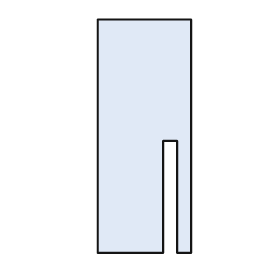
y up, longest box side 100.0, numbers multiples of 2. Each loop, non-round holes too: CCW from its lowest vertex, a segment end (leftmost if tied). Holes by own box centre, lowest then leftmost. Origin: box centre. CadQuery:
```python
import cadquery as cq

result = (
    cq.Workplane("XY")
    .moveTo(-20.0, -50.0)
    .lineTo(8.0, -50.0)
    .lineTo(8.0, -2.0)
    .lineTo(14.0, -2.0)
    .lineTo(14.0, -50.0)
    .lineTo(20.0, -50.0)
    .lineTo(20.0, 50.0)
    .lineTo(-20.0, 50.0)
    .close()
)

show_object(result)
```